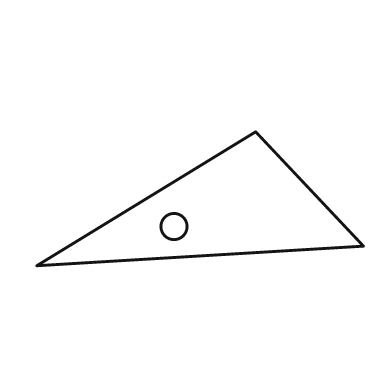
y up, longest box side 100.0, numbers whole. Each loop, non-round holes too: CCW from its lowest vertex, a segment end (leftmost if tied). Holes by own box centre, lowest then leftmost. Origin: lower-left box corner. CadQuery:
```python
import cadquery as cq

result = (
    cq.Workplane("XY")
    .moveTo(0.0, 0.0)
    .lineTo(100.0, 6.0)
    .lineTo(67.0, 41.0)
    .close()
    .moveTo(42.0, 12.0)
    .circle(4.0)
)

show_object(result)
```